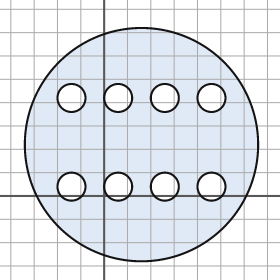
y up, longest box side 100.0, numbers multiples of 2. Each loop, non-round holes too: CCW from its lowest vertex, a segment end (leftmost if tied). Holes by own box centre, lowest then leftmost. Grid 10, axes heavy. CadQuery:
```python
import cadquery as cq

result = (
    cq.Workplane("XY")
    .moveTo(16.0, 22.0)
    .circle(50.0)
    .moveTo(-14.0, 4.0)
    .circle(6.0)
    .moveTo(6.0, 4.0)
    .circle(6.0)
    .moveTo(26.0, 4.0)
    .circle(6.0)
    .moveTo(46.0, 4.0)
    .circle(6.0)
    .moveTo(-14.0, 42.0)
    .circle(6.0)
    .moveTo(6.0, 42.0)
    .circle(6.0)
    .moveTo(26.0, 42.0)
    .circle(6.0)
    .moveTo(46.0, 42.0)
    .circle(6.0)
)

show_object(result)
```